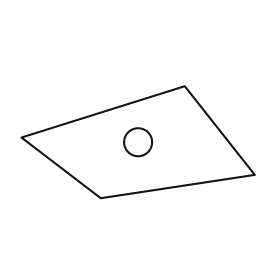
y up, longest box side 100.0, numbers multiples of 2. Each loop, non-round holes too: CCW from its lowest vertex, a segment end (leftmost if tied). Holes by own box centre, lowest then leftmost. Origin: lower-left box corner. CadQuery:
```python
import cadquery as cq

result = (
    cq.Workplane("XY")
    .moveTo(34.0, 0.0)
    .lineTo(100.0, 10.0)
    .lineTo(70.0, 48.0)
    .lineTo(0.0, 26.0)
    .close()
    .moveTo(50.0, 24.0)
    .circle(6.0)
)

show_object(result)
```